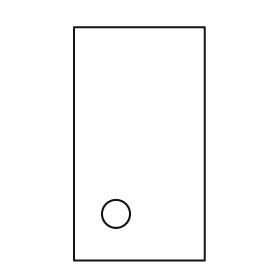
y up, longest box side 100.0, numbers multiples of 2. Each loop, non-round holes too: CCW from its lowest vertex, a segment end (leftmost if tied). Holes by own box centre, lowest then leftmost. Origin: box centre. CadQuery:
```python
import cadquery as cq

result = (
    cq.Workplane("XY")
    .moveTo(-28.0, -50.0)
    .lineTo(28.0, -50.0)
    .lineTo(28.0, 50.0)
    .lineTo(-28.0, 50.0)
    .close()
    .moveTo(-10.0, -30.0)
    .circle(6.0)
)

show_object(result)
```